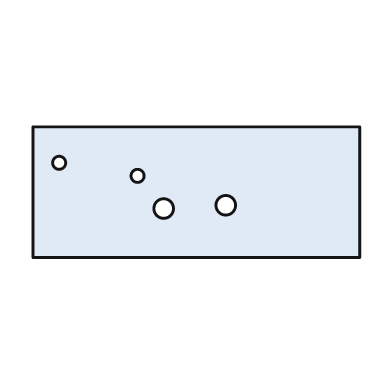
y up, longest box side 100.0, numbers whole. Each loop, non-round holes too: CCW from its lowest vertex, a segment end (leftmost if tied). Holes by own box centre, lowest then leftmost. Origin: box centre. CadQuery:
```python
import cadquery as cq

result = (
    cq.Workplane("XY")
    .moveTo(-50.0, -20.0)
    .lineTo(50.0, -20.0)
    .lineTo(50.0, 20.0)
    .lineTo(-50.0, 20.0)
    .close()
    .moveTo(-10.0, -5.0)
    .circle(3.0)
    .moveTo(9.0, -4.0)
    .circle(3.0)
    .moveTo(-18.0, 5.0)
    .circle(2.0)
    .moveTo(-42.0, 9.0)
    .circle(2.0)
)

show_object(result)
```